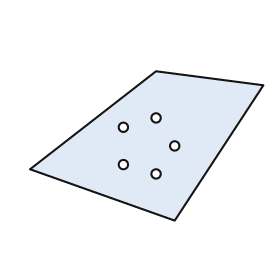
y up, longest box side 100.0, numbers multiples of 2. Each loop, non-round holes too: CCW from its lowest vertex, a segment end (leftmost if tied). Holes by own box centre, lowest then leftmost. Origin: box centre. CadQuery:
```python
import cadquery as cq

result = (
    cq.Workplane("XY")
    .moveTo(12.0, -32.0)
    .lineTo(50.0, 26.0)
    .lineTo(4.0, 32.0)
    .lineTo(-50.0, -10.0)
    .close()
    .moveTo(4.0, -12.0)
    .circle(2.0)
    .moveTo(-10.0, -8.0)
    .circle(2.0)
    .moveTo(12.0, 0.0)
    .circle(2.0)
    .moveTo(-10.0, 8.0)
    .circle(2.0)
    .moveTo(4.0, 12.0)
    .circle(2.0)
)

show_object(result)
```